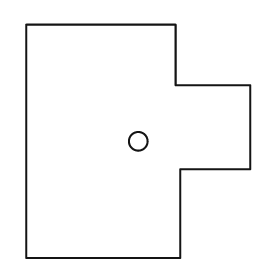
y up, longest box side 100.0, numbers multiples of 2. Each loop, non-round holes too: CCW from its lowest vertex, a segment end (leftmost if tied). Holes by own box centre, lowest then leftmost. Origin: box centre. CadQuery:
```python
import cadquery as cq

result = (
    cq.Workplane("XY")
    .moveTo(-48.0, -50.0)
    .lineTo(18.0, -50.0)
    .lineTo(18.0, -12.0)
    .lineTo(48.0, -12.0)
    .lineTo(48.0, 24.0)
    .lineTo(16.0, 24.0)
    .lineTo(16.0, 50.0)
    .lineTo(-48.0, 50.0)
    .close()
    .moveTo(0.0, 0.0)
    .circle(4.0)
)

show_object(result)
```